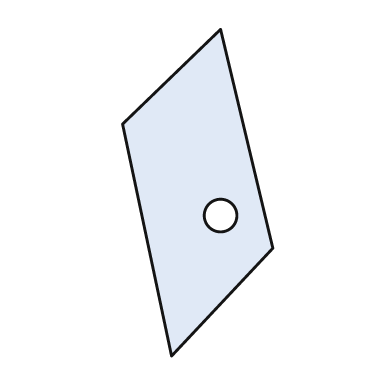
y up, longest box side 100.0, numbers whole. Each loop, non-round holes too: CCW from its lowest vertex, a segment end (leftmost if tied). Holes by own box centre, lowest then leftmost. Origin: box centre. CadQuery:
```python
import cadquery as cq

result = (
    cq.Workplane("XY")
    .moveTo(-8.0, -50.0)
    .lineTo(23.0, -17.0)
    .lineTo(7.0, 50.0)
    .lineTo(-23.0, 21.0)
    .close()
    .moveTo(7.0, -7.0)
    .circle(5.0)
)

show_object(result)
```